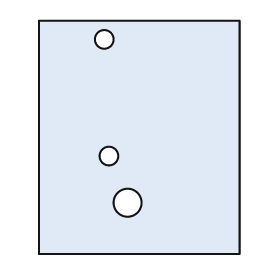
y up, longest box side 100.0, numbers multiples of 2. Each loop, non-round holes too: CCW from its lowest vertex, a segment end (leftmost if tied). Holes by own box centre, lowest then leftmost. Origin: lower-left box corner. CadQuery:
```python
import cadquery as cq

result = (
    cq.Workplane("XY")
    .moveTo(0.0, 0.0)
    .lineTo(86.0, 0.0)
    .lineTo(86.0, 100.0)
    .lineTo(0.0, 100.0)
    .close()
    .moveTo(38.0, 22.0)
    .circle(6.0)
    .moveTo(30.0, 42.0)
    .circle(4.0)
    .moveTo(28.0, 92.0)
    .circle(4.0)
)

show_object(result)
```